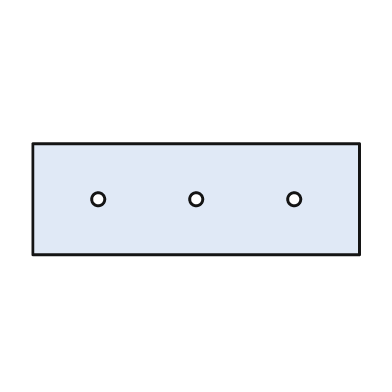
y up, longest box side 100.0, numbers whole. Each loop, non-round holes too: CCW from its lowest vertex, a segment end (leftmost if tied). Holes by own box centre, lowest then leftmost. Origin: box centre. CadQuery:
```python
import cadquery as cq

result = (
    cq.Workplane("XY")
    .moveTo(-50.0, -17.0)
    .lineTo(50.0, -17.0)
    .lineTo(50.0, 17.0)
    .lineTo(-50.0, 17.0)
    .close()
    .moveTo(-30.0, 0.0)
    .circle(2.0)
    .moveTo(0.0, 0.0)
    .circle(2.0)
    .moveTo(30.0, 0.0)
    .circle(2.0)
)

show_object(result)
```